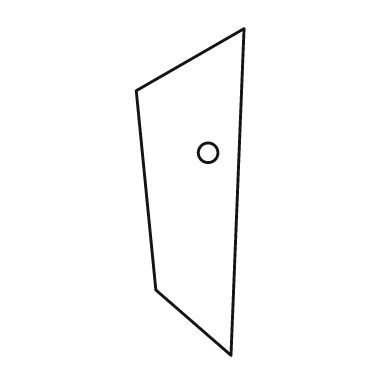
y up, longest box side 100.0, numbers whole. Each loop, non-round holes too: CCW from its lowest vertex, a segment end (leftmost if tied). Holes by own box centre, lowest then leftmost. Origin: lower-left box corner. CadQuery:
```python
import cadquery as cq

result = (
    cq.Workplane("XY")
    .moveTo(29.0, 0.0)
    .lineTo(33.0, 100.0)
    .lineTo(0.0, 81.0)
    .lineTo(6.0, 20.0)
    .close()
    .moveTo(22.0, 62.0)
    .circle(3.0)
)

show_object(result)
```